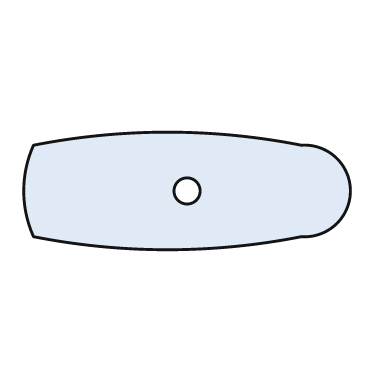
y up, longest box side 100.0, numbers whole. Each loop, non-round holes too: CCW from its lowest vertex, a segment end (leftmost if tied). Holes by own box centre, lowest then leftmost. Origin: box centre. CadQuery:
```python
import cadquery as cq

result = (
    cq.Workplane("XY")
    .moveTo(-47.0, -14.0)
    .threePointArc((-6.0, -18.0), (35.0, -14.0))
    .threePointArc((50.0, 0.0), (35.0, 14.0))
    .threePointArc((-6.0, 18.0), (-47.0, 14.0))
    .threePointArc((-50.0, 0.0), (-47.0, -14.0))
    .close()
    .moveTo(0.0, 0.0)
    .circle(4.0)
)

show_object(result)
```